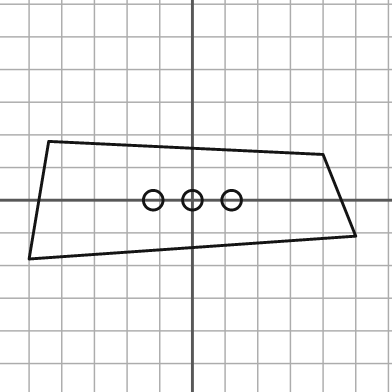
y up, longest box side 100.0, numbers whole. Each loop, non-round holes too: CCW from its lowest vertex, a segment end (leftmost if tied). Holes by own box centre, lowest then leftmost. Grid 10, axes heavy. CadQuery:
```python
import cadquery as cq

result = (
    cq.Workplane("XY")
    .moveTo(-50.0, -18.0)
    .lineTo(50.0, -11.0)
    .lineTo(40.0, 14.0)
    .lineTo(-44.0, 18.0)
    .close()
    .moveTo(-12.0, 0.0)
    .circle(3.0)
    .moveTo(0.0, 0.0)
    .circle(3.0)
    .moveTo(12.0, 0.0)
    .circle(3.0)
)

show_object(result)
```